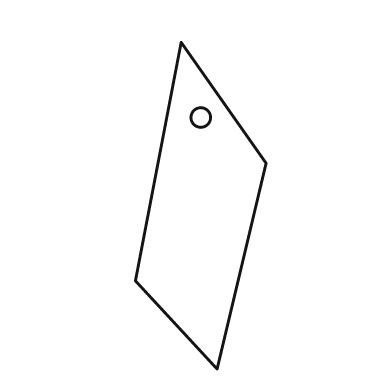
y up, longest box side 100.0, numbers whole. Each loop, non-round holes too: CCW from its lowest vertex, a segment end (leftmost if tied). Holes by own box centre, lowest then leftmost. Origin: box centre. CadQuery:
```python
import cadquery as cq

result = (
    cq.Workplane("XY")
    .moveTo(5.0, -50.0)
    .lineTo(20.0, 13.0)
    .lineTo(-6.0, 50.0)
    .lineTo(-20.0, -23.0)
    .close()
    .moveTo(0.0, 27.0)
    .circle(3.0)
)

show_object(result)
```